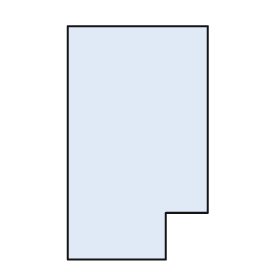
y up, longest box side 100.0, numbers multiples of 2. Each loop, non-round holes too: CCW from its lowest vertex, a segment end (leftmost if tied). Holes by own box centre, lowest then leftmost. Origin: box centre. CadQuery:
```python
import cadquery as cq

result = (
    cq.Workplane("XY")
    .moveTo(-30.0, -50.0)
    .lineTo(12.0, -50.0)
    .lineTo(12.0, -30.0)
    .lineTo(30.0, -30.0)
    .lineTo(30.0, 50.0)
    .lineTo(-30.0, 50.0)
    .close()
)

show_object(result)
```